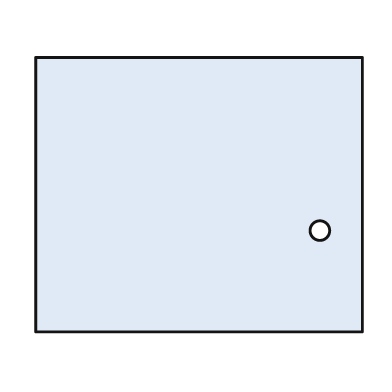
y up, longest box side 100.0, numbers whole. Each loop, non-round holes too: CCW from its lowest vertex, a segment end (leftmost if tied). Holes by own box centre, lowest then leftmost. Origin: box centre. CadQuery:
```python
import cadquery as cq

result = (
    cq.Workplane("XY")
    .moveTo(-50.0, -42.0)
    .lineTo(50.0, -42.0)
    .lineTo(50.0, 42.0)
    .lineTo(-50.0, 42.0)
    .close()
    .moveTo(37.0, -11.0)
    .circle(3.0)
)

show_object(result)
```